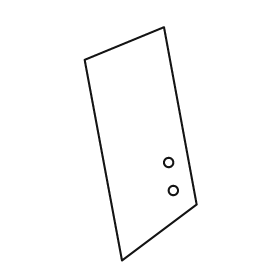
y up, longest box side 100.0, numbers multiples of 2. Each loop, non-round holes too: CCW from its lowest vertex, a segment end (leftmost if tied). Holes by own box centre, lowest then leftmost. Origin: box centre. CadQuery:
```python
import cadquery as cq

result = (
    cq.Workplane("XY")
    .moveTo(-8.0, -50.0)
    .lineTo(24.0, -26.0)
    .lineTo(10.0, 50.0)
    .lineTo(-24.0, 36.0)
    .close()
    .moveTo(14.0, -20.0)
    .circle(2.0)
    .moveTo(12.0, -8.0)
    .circle(2.0)
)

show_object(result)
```